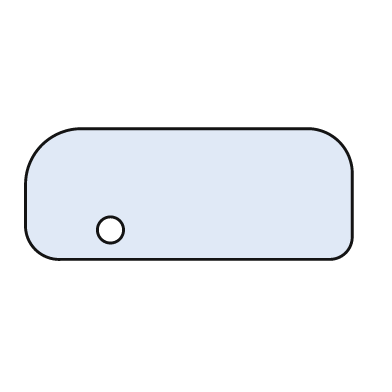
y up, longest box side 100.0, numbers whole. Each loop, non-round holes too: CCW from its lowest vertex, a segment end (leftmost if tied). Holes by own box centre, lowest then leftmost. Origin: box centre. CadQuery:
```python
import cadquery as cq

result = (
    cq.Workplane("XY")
    .moveTo(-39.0, -20.0)
    .lineTo(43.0, -20.0)
    .threePointArc((48.0, -18.0), (50.0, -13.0))
    .lineTo(50.0, 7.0)
    .threePointArc((46.0, 16.0), (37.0, 20.0))
    .lineTo(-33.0, 20.0)
    .threePointArc((-45.0, 15.0), (-50.0, 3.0))
    .lineTo(-50.0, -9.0)
    .threePointArc((-47.0, -17.0), (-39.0, -20.0))
    .close()
    .moveTo(-24.0, -11.0)
    .circle(4.0)
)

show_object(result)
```